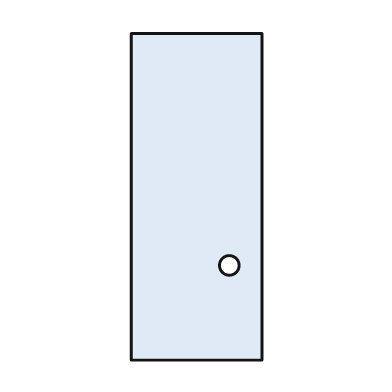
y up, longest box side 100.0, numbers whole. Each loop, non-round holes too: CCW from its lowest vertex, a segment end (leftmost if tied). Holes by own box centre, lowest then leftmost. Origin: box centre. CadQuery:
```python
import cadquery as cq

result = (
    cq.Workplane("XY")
    .moveTo(-20.0, -50.0)
    .lineTo(20.0, -50.0)
    .lineTo(20.0, 50.0)
    .lineTo(-20.0, 50.0)
    .close()
    .moveTo(10.0, -21.0)
    .circle(3.0)
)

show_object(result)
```